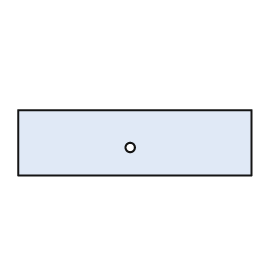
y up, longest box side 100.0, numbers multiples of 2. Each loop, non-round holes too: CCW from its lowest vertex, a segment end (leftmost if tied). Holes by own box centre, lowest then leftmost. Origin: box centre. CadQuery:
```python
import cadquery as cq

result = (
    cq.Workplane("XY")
    .moveTo(-50.0, -14.0)
    .lineTo(50.0, -14.0)
    .lineTo(50.0, 14.0)
    .lineTo(-50.0, 14.0)
    .close()
    .moveTo(-2.0, -2.0)
    .circle(2.0)
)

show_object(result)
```